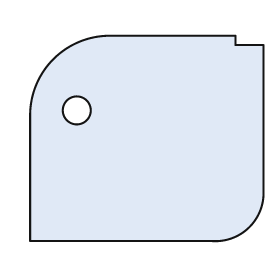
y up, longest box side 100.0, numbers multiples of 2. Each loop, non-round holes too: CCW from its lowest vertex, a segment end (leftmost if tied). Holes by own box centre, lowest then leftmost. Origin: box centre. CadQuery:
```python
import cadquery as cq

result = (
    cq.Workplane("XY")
    .moveTo(-50.0, -44.0)
    .lineTo(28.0, -44.0)
    .threePointArc((44.0, -38.0), (50.0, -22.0))
    .lineTo(50.0, 40.0)
    .lineTo(38.0, 40.0)
    .lineTo(38.0, 44.0)
    .lineTo(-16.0, 44.0)
    .threePointArc((-40.0, 34.0), (-50.0, 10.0))
    .close()
    .moveTo(-30.0, 12.0)
    .circle(6.0)
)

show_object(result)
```